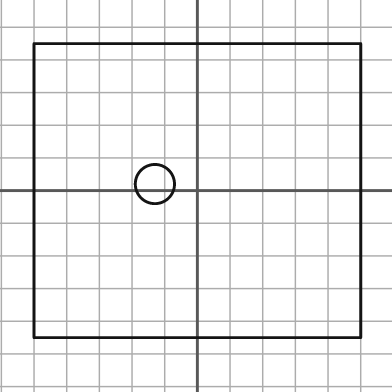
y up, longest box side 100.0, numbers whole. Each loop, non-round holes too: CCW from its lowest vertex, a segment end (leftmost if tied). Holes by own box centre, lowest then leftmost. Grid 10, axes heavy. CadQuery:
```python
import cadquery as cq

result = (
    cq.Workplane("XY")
    .moveTo(-50.0, -45.0)
    .lineTo(50.0, -45.0)
    .lineTo(50.0, 45.0)
    .lineTo(-50.0, 45.0)
    .close()
    .moveTo(-13.0, 2.0)
    .circle(6.0)
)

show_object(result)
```